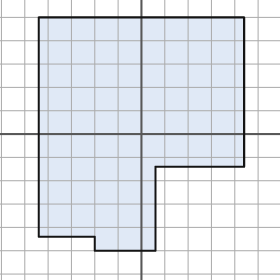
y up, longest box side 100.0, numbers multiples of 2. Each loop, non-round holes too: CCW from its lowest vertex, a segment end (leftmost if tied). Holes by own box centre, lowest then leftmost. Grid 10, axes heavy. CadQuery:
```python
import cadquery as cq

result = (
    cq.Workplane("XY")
    .moveTo(-20.0, -50.0)
    .lineTo(6.0, -50.0)
    .lineTo(6.0, -14.0)
    .lineTo(44.0, -14.0)
    .lineTo(44.0, 50.0)
    .lineTo(-44.0, 50.0)
    .lineTo(-44.0, -44.0)
    .lineTo(-20.0, -44.0)
    .close()
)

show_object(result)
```